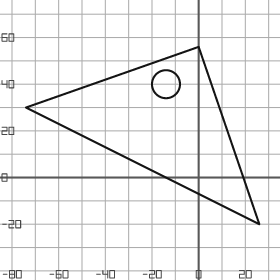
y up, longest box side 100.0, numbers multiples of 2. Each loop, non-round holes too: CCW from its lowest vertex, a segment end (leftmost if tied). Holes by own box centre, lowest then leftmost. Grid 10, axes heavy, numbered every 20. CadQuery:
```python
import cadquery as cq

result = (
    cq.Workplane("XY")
    .moveTo(26.0, -20.0)
    .lineTo(0.0, 56.0)
    .lineTo(-74.0, 30.0)
    .close()
    .moveTo(-14.0, 40.0)
    .circle(6.0)
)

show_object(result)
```